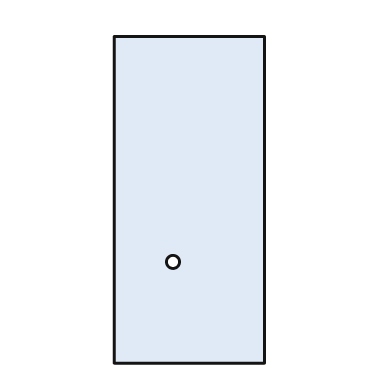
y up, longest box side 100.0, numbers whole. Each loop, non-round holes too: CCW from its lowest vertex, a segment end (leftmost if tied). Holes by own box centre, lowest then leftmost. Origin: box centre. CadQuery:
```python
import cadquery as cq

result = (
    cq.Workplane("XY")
    .moveTo(-23.0, -50.0)
    .lineTo(23.0, -50.0)
    .lineTo(23.0, 50.0)
    .lineTo(-23.0, 50.0)
    .close()
    .moveTo(-5.0, -19.0)
    .circle(2.0)
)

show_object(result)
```